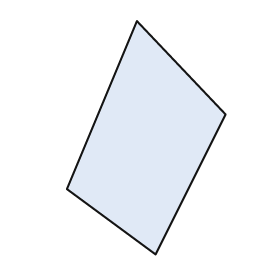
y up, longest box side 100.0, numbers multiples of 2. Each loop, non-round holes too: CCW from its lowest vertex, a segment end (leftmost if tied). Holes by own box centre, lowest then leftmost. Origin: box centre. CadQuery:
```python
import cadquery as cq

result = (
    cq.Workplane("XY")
    .moveTo(4.0, -50.0)
    .lineTo(34.0, 10.0)
    .lineTo(-4.0, 50.0)
    .lineTo(-34.0, -22.0)
    .close()
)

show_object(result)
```